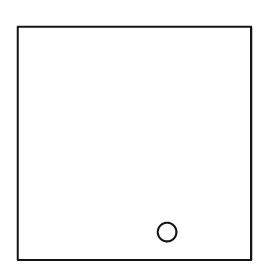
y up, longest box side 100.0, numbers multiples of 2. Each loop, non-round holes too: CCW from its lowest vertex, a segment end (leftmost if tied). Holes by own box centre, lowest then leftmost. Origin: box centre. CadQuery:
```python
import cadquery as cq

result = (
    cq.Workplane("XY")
    .moveTo(-50.0, -50.0)
    .lineTo(50.0, -50.0)
    .lineTo(50.0, 50.0)
    .lineTo(-50.0, 50.0)
    .close()
    .moveTo(14.0, -38.0)
    .circle(4.0)
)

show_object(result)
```